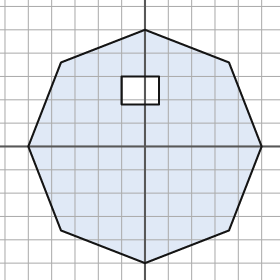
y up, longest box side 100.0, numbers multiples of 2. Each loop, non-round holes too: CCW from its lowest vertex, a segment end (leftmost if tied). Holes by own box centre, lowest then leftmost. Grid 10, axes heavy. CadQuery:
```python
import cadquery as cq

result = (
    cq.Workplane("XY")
    .moveTo(0.0, -50.0)
    .lineTo(36.0, -36.0)
    .lineTo(50.0, 0.0)
    .lineTo(36.0, 36.0)
    .lineTo(0.0, 50.0)
    .lineTo(-36.0, 36.0)
    .lineTo(-50.0, 0.0)
    .lineTo(-36.0, -36.0)
    .close()
    .moveTo(-10.0, 18.0)
    .lineTo(6.0, 18.0)
    .lineTo(6.0, 30.0)
    .lineTo(-10.0, 30.0)
    .close()
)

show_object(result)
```